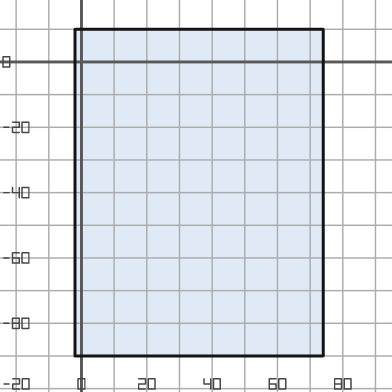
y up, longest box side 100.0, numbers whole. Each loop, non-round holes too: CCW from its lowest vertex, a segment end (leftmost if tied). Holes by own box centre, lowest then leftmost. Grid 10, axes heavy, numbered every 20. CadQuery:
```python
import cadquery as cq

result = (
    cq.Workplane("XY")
    .moveTo(-2.0, -90.0)
    .lineTo(74.0, -90.0)
    .lineTo(74.0, 10.0)
    .lineTo(-2.0, 10.0)
    .close()
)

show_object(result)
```